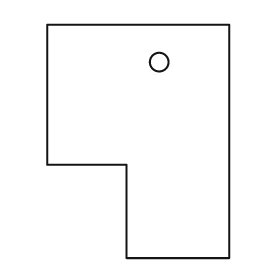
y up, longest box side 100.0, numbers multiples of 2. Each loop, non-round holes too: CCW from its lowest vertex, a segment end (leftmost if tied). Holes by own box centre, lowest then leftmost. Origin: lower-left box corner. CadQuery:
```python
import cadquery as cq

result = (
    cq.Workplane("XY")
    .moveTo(34.0, 0.0)
    .lineTo(78.0, 0.0)
    .lineTo(78.0, 100.0)
    .lineTo(0.0, 100.0)
    .lineTo(0.0, 40.0)
    .lineTo(34.0, 40.0)
    .close()
    .moveTo(48.0, 84.0)
    .circle(4.0)
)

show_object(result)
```